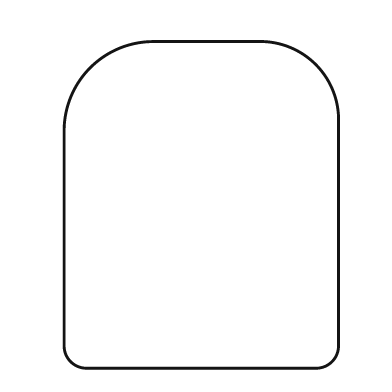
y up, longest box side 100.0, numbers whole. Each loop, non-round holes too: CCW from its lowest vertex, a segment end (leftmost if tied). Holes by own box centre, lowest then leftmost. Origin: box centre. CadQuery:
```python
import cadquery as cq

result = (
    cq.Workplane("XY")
    .moveTo(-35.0, -50.0)
    .lineTo(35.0, -50.0)
    .threePointArc((40.0, -48.0), (42.0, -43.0))
    .lineTo(42.0, 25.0)
    .threePointArc((35.0, 43.0), (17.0, 50.0))
    .lineTo(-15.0, 50.0)
    .threePointArc((-34.0, 42.0), (-42.0, 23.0))
    .lineTo(-42.0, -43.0)
    .threePointArc((-40.0, -48.0), (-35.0, -50.0))
    .close()
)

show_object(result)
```